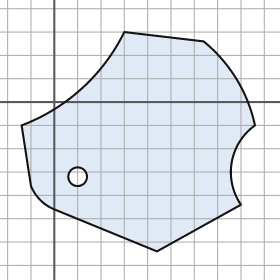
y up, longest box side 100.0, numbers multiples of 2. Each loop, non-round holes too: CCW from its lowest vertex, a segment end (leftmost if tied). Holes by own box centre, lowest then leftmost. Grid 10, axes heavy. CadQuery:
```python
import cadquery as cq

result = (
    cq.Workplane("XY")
    .moveTo(44.0, -64.0)
    .lineTo(80.0, -44.0)
    .threePointArc((76.0, -26.0), (86.0, -10.0))
    .threePointArc((78.0, 10.0), (64.0, 26.0))
    .lineTo(30.0, 30.0)
    .threePointArc((12.0, 6.0), (-14.0, -10.0))
    .lineTo(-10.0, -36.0)
    .threePointArc((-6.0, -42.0), (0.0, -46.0))
    .close()
    .moveTo(10.0, -32.0)
    .circle(4.0)
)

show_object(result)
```